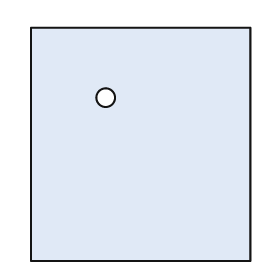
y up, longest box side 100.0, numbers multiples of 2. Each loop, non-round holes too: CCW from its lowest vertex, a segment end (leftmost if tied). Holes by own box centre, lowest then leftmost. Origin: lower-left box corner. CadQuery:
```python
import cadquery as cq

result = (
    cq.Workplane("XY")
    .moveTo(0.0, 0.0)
    .lineTo(94.0, 0.0)
    .lineTo(94.0, 100.0)
    .lineTo(0.0, 100.0)
    .close()
    .moveTo(32.0, 70.0)
    .circle(4.0)
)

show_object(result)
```